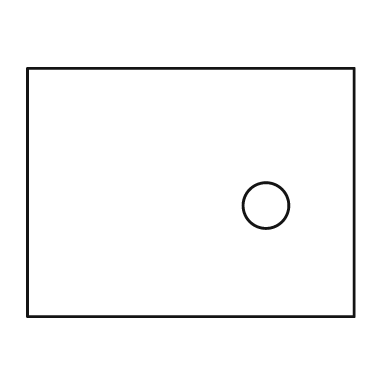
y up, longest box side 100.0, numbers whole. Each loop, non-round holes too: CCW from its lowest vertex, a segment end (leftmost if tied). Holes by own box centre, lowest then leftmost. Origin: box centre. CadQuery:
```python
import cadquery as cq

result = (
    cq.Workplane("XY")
    .moveTo(-50.0, -38.0)
    .lineTo(50.0, -38.0)
    .lineTo(50.0, 38.0)
    .lineTo(-50.0, 38.0)
    .close()
    .moveTo(23.0, -4.0)
    .circle(7.0)
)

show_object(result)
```